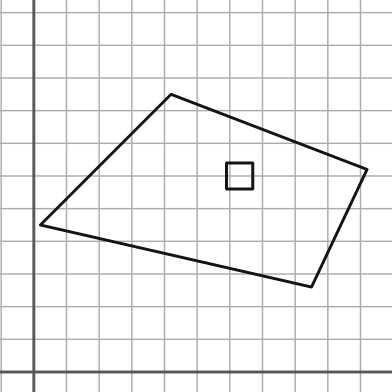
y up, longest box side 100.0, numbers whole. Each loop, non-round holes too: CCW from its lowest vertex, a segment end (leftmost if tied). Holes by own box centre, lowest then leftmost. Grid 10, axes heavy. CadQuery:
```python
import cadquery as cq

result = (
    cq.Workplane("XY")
    .moveTo(85.0, 26.0)
    .lineTo(102.0, 62.0)
    .lineTo(42.0, 85.0)
    .lineTo(2.0, 45.0)
    .close()
    .moveTo(59.0, 56.0)
    .lineTo(67.0, 56.0)
    .lineTo(67.0, 64.0)
    .lineTo(59.0, 64.0)
    .close()
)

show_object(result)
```